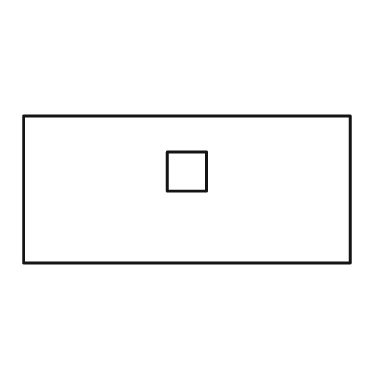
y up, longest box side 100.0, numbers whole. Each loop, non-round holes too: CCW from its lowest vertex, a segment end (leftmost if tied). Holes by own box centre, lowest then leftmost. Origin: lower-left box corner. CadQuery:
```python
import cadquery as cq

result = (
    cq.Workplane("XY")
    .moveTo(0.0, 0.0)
    .lineTo(100.0, 0.0)
    .lineTo(100.0, 45.0)
    .lineTo(0.0, 45.0)
    .close()
    .moveTo(44.0, 22.0)
    .lineTo(56.0, 22.0)
    .lineTo(56.0, 34.0)
    .lineTo(44.0, 34.0)
    .close()
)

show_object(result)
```